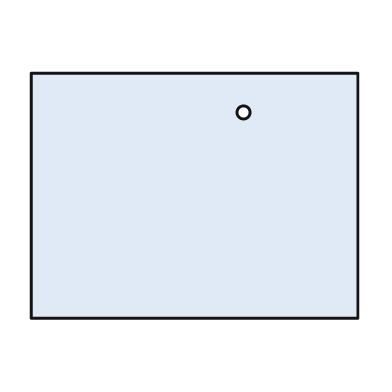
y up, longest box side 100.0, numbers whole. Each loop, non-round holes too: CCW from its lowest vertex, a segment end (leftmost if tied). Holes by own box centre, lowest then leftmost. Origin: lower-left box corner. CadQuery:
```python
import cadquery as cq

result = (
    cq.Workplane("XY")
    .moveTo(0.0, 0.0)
    .lineTo(100.0, 0.0)
    .lineTo(100.0, 75.0)
    .lineTo(0.0, 75.0)
    .close()
    .moveTo(65.0, 63.0)
    .circle(2.0)
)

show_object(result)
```